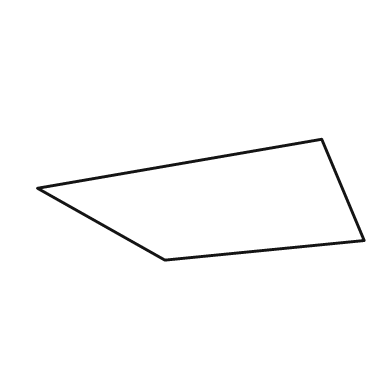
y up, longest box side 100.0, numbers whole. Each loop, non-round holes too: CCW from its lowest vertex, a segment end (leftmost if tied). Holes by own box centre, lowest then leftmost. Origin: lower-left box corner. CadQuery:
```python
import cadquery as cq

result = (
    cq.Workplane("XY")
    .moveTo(39.0, 0.0)
    .lineTo(100.0, 6.0)
    .lineTo(87.0, 37.0)
    .lineTo(0.0, 22.0)
    .close()
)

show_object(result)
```